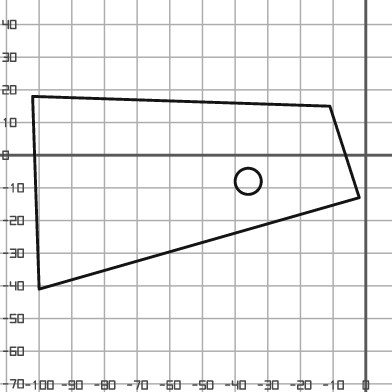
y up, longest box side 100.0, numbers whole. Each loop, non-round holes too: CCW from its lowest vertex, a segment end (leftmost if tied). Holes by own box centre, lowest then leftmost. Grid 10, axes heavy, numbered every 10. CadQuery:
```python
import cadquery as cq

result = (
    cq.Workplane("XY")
    .moveTo(-100.0, -41.0)
    .lineTo(-2.0, -13.0)
    .lineTo(-11.0, 15.0)
    .lineTo(-102.0, 18.0)
    .close()
    .moveTo(-36.0, -8.0)
    .circle(4.0)
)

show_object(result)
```